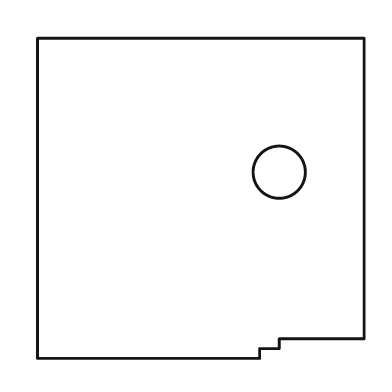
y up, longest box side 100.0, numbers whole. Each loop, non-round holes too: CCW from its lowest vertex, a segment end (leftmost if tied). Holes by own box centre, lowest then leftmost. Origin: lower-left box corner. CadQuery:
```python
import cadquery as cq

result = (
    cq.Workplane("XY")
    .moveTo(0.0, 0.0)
    .lineTo(68.0, 0.0)
    .lineTo(68.0, 3.0)
    .lineTo(74.0, 3.0)
    .lineTo(74.0, 6.0)
    .lineTo(100.0, 6.0)
    .lineTo(100.0, 98.0)
    .lineTo(0.0, 98.0)
    .close()
    .moveTo(74.0, 57.0)
    .circle(8.0)
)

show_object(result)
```